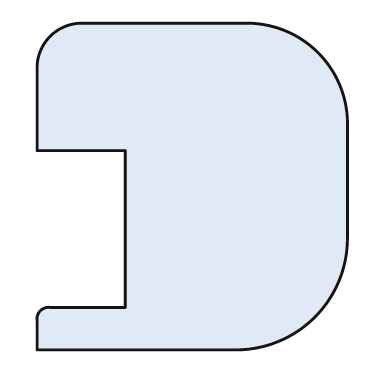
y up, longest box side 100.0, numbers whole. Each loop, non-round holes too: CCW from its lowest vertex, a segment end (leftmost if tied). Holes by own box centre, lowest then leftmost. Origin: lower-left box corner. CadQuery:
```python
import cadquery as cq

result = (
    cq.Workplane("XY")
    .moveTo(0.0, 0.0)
    .lineTo(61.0, 0.0)
    .threePointArc((85.0, 10.0), (95.0, 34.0))
    .lineTo(95.0, 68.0)
    .threePointArc((86.0, 91.0), (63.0, 100.0))
    .lineTo(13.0, 100.0)
    .threePointArc((4.0, 96.0), (0.0, 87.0))
    .lineTo(0.0, 61.0)
    .lineTo(27.0, 61.0)
    .lineTo(27.0, 13.0)
    .lineTo(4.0, 13.0)
    .threePointArc((1.0, 12.0), (0.0, 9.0))
    .close()
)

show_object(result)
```